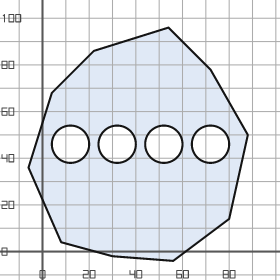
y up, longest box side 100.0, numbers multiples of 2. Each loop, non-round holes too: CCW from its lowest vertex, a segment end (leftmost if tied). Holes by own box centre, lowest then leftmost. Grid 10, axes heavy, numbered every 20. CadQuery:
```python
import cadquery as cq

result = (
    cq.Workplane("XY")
    .moveTo(56.0, -4.0)
    .lineTo(80.0, 14.0)
    .lineTo(88.0, 50.0)
    .lineTo(72.0, 78.0)
    .lineTo(54.0, 96.0)
    .lineTo(22.0, 86.0)
    .lineTo(4.0, 68.0)
    .lineTo(-6.0, 36.0)
    .lineTo(8.0, 4.0)
    .lineTo(30.0, -2.0)
    .close()
    .moveTo(12.0, 46.0)
    .circle(8.0)
    .moveTo(32.0, 46.0)
    .circle(8.0)
    .moveTo(52.0, 46.0)
    .circle(8.0)
    .moveTo(72.0, 46.0)
    .circle(8.0)
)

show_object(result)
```